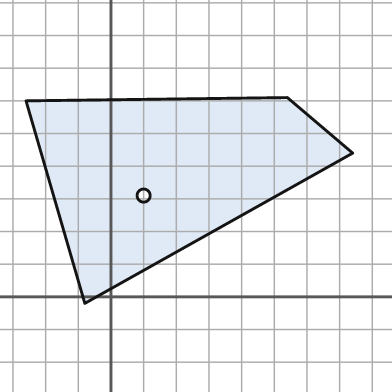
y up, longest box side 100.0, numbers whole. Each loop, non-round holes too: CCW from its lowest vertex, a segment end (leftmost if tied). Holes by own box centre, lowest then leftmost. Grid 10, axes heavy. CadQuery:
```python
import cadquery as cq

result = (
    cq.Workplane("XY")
    .moveTo(-8.0, -2.0)
    .lineTo(74.0, 44.0)
    .lineTo(54.0, 61.0)
    .lineTo(-26.0, 60.0)
    .close()
    .moveTo(10.0, 31.0)
    .circle(2.0)
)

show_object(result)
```